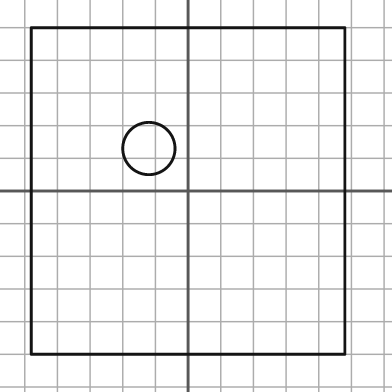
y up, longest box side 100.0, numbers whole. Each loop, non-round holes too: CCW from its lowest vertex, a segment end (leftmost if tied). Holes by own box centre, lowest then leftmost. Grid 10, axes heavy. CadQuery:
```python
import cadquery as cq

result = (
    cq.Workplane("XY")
    .moveTo(-48.0, -50.0)
    .lineTo(48.0, -50.0)
    .lineTo(48.0, 50.0)
    .lineTo(-48.0, 50.0)
    .close()
    .moveTo(-12.0, 13.0)
    .circle(8.0)
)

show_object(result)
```